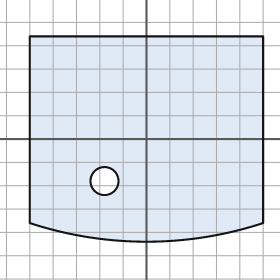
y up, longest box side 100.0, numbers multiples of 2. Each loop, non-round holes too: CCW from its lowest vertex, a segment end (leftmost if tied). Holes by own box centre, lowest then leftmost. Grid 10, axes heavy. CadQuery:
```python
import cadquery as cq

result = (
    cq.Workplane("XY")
    .moveTo(-50.0, -36.0)
    .threePointArc((0.0, -44.0), (50.0, -36.0))
    .lineTo(50.0, 44.0)
    .lineTo(-50.0, 44.0)
    .close()
    .moveTo(-18.0, -18.0)
    .circle(6.0)
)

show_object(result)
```